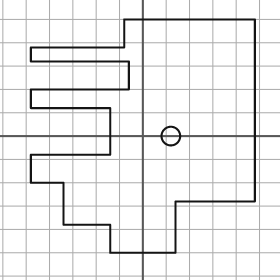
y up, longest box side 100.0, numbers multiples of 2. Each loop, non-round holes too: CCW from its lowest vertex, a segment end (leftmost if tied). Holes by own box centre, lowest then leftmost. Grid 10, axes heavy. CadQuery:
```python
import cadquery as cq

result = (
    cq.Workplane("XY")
    .moveTo(-14.0, -50.0)
    .lineTo(14.0, -50.0)
    .lineTo(14.0, -28.0)
    .lineTo(48.0, -28.0)
    .lineTo(48.0, 50.0)
    .lineTo(-8.0, 50.0)
    .lineTo(-8.0, 38.0)
    .lineTo(-48.0, 38.0)
    .lineTo(-48.0, 32.0)
    .lineTo(-6.0, 32.0)
    .lineTo(-6.0, 20.0)
    .lineTo(-48.0, 20.0)
    .lineTo(-48.0, 12.0)
    .lineTo(-14.0, 12.0)
    .lineTo(-14.0, -8.0)
    .lineTo(-48.0, -8.0)
    .lineTo(-48.0, -20.0)
    .lineTo(-34.0, -20.0)
    .lineTo(-34.0, -38.0)
    .lineTo(-14.0, -38.0)
    .close()
    .moveTo(12.0, 0.0)
    .circle(4.0)
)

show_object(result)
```